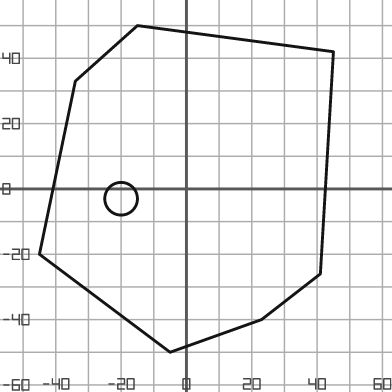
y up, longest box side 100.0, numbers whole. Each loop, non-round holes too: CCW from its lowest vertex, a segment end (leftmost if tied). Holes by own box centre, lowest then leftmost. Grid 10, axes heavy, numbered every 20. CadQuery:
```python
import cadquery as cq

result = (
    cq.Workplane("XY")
    .moveTo(-5.0, -50.0)
    .lineTo(23.0, -40.0)
    .lineTo(41.0, -26.0)
    .lineTo(45.0, 42.0)
    .lineTo(-15.0, 50.0)
    .lineTo(-34.0, 33.0)
    .lineTo(-45.0, -20.0)
    .close()
    .moveTo(-20.0, -3.0)
    .circle(5.0)
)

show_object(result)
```